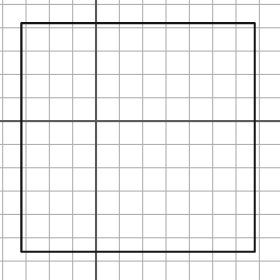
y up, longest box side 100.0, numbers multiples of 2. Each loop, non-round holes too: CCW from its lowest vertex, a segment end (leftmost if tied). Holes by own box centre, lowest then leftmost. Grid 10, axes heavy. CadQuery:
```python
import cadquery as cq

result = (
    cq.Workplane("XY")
    .moveTo(-32.0, -56.0)
    .lineTo(68.0, -56.0)
    .lineTo(68.0, 42.0)
    .lineTo(-32.0, 42.0)
    .close()
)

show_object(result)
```